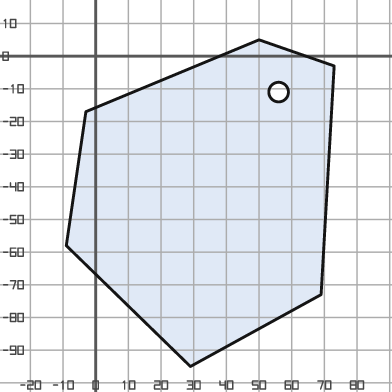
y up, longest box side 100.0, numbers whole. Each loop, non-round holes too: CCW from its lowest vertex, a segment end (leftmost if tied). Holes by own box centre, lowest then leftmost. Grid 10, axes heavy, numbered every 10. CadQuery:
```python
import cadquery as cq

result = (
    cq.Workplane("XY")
    .moveTo(29.0, -95.0)
    .lineTo(69.0, -73.0)
    .lineTo(73.0, -3.0)
    .lineTo(50.0, 5.0)
    .lineTo(-3.0, -17.0)
    .lineTo(-9.0, -58.0)
    .close()
    .moveTo(56.0, -11.0)
    .circle(3.0)
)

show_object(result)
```